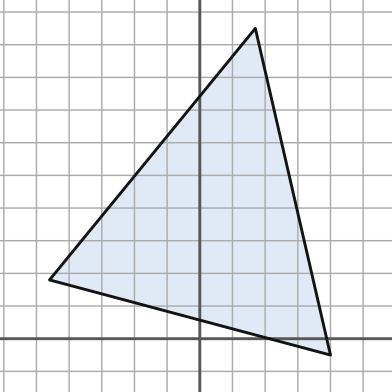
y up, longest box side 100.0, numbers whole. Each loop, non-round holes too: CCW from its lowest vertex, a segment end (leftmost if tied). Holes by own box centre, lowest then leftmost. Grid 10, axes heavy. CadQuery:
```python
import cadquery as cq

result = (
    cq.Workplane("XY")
    .moveTo(40.0, -5.0)
    .lineTo(17.0, 95.0)
    .lineTo(-46.0, 18.0)
    .close()
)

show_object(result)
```